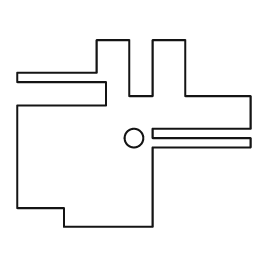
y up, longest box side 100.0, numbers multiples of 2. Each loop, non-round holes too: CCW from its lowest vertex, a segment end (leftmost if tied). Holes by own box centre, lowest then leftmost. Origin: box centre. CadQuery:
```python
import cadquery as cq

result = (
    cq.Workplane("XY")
    .moveTo(-30.0, -40.0)
    .lineTo(8.0, -40.0)
    .lineTo(8.0, -6.0)
    .lineTo(50.0, -6.0)
    .lineTo(50.0, -2.0)
    .lineTo(8.0, -2.0)
    .lineTo(8.0, 2.0)
    .lineTo(50.0, 2.0)
    .lineTo(50.0, 16.0)
    .lineTo(22.0, 16.0)
    .lineTo(22.0, 40.0)
    .lineTo(8.0, 40.0)
    .lineTo(8.0, 16.0)
    .lineTo(-2.0, 16.0)
    .lineTo(-2.0, 40.0)
    .lineTo(-16.0, 40.0)
    .lineTo(-16.0, 26.0)
    .lineTo(-50.0, 26.0)
    .lineTo(-50.0, 22.0)
    .lineTo(-12.0, 22.0)
    .lineTo(-12.0, 12.0)
    .lineTo(-50.0, 12.0)
    .lineTo(-50.0, -32.0)
    .lineTo(-30.0, -32.0)
    .close()
    .moveTo(0.0, -2.0)
    .circle(4.0)
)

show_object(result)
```